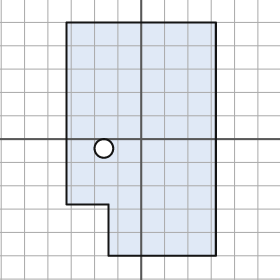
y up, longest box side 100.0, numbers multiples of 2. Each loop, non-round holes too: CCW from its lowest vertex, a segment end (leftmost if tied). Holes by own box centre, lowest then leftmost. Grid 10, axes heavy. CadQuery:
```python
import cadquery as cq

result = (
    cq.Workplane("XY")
    .moveTo(-14.0, -50.0)
    .lineTo(32.0, -50.0)
    .lineTo(32.0, 50.0)
    .lineTo(-32.0, 50.0)
    .lineTo(-32.0, -28.0)
    .lineTo(-14.0, -28.0)
    .close()
    .moveTo(-16.0, -4.0)
    .circle(4.0)
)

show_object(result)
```